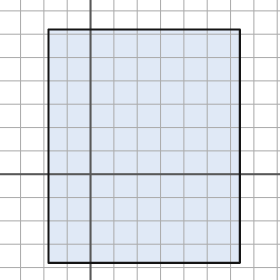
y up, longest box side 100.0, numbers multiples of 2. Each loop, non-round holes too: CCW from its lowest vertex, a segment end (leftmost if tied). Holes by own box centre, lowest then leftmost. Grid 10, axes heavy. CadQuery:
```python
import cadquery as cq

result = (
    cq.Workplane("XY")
    .moveTo(-18.0, -38.0)
    .lineTo(64.0, -38.0)
    .lineTo(64.0, 62.0)
    .lineTo(-18.0, 62.0)
    .close()
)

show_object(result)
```